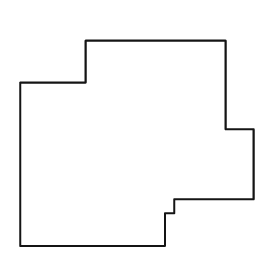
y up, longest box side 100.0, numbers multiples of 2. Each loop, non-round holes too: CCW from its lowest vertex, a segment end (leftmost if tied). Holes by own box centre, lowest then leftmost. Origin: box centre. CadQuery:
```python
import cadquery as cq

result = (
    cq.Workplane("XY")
    .moveTo(-50.0, -44.0)
    .lineTo(12.0, -44.0)
    .lineTo(12.0, -30.0)
    .lineTo(16.0, -30.0)
    .lineTo(16.0, -24.0)
    .lineTo(50.0, -24.0)
    .lineTo(50.0, 6.0)
    .lineTo(38.0, 6.0)
    .lineTo(38.0, 44.0)
    .lineTo(-22.0, 44.0)
    .lineTo(-22.0, 26.0)
    .lineTo(-50.0, 26.0)
    .close()
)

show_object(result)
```